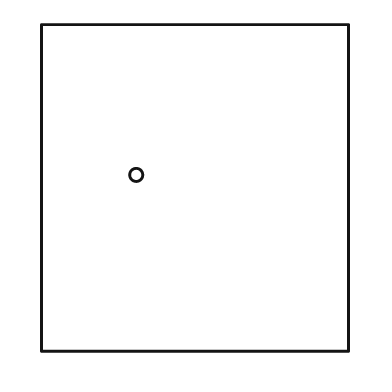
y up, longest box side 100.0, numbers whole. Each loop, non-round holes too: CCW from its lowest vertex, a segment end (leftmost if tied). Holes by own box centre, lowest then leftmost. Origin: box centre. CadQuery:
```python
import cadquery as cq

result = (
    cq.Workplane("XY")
    .moveTo(-47.0, -50.0)
    .lineTo(47.0, -50.0)
    .lineTo(47.0, 50.0)
    .lineTo(-47.0, 50.0)
    .close()
    .moveTo(-18.0, 4.0)
    .circle(2.0)
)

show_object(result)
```